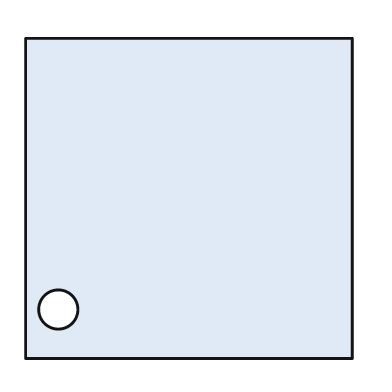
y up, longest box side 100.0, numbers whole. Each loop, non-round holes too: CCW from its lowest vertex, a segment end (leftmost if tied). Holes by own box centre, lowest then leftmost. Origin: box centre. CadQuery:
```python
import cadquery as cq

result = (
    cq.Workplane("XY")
    .moveTo(-50.0, -49.0)
    .lineTo(50.0, -49.0)
    .lineTo(50.0, 49.0)
    .lineTo(-50.0, 49.0)
    .close()
    .moveTo(-40.0, -34.0)
    .circle(6.0)
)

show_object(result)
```